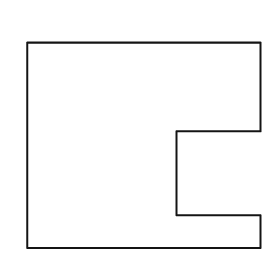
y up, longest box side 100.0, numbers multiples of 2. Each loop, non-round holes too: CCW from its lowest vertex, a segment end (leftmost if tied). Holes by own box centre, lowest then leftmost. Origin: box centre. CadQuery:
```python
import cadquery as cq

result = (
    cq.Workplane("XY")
    .moveTo(-50.0, -44.0)
    .lineTo(50.0, -44.0)
    .lineTo(50.0, -30.0)
    .lineTo(14.0, -30.0)
    .lineTo(14.0, 6.0)
    .lineTo(50.0, 6.0)
    .lineTo(50.0, 44.0)
    .lineTo(-50.0, 44.0)
    .close()
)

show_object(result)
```